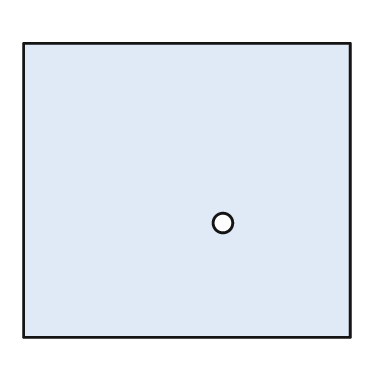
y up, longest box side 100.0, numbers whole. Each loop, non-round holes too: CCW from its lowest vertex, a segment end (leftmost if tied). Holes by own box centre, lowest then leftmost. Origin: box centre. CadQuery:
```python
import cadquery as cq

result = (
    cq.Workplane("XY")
    .moveTo(-50.0, -45.0)
    .lineTo(50.0, -45.0)
    .lineTo(50.0, 45.0)
    .lineTo(-50.0, 45.0)
    .close()
    .moveTo(11.0, -10.0)
    .circle(3.0)
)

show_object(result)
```